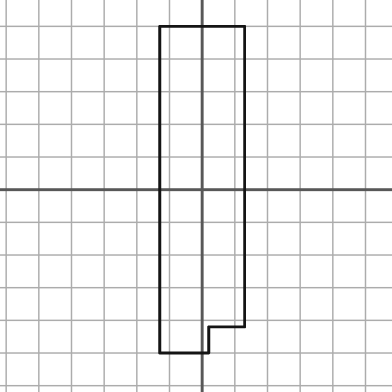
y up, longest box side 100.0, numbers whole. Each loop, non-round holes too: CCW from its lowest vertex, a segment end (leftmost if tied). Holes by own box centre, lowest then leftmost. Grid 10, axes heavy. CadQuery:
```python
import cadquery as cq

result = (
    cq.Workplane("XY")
    .moveTo(-13.0, -50.0)
    .lineTo(2.0, -50.0)
    .lineTo(2.0, -42.0)
    .lineTo(13.0, -42.0)
    .lineTo(13.0, 50.0)
    .lineTo(-13.0, 50.0)
    .close()
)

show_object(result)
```